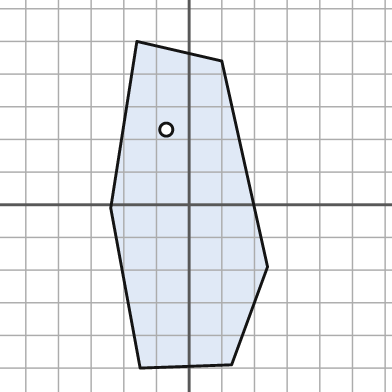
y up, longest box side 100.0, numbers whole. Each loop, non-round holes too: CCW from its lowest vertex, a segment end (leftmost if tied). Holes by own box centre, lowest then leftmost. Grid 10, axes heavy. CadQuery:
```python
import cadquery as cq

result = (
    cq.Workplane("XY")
    .moveTo(-15.0, -50.0)
    .lineTo(13.0, -49.0)
    .lineTo(24.0, -19.0)
    .lineTo(10.0, 44.0)
    .lineTo(-16.0, 50.0)
    .lineTo(-24.0, -1.0)
    .close()
    .moveTo(-7.0, 23.0)
    .circle(2.0)
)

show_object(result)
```